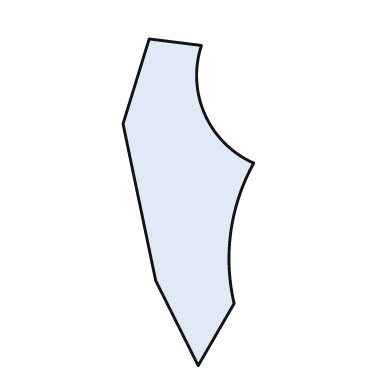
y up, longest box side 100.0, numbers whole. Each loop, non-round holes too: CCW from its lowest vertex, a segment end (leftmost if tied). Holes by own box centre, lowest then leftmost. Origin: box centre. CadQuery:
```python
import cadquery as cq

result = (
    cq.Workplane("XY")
    .moveTo(3.0, -50.0)
    .lineTo(14.0, -31.0)
    .threePointArc((13.0, -9.0), (20.0, 12.0))
    .threePointArc((5.0, 27.0), (4.0, 48.0))
    .lineTo(-12.0, 50.0)
    .lineTo(-20.0, 24.0)
    .lineTo(-10.0, -24.0)
    .close()
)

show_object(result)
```